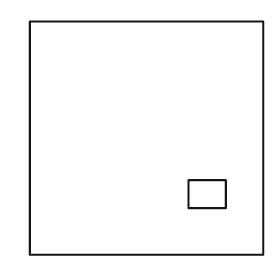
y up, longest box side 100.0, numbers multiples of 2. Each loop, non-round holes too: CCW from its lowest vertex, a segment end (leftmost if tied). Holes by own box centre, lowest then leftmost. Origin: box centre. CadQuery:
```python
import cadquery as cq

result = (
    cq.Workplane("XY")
    .moveTo(-50.0, -50.0)
    .lineTo(50.0, -50.0)
    .lineTo(50.0, 50.0)
    .lineTo(-50.0, 50.0)
    .close()
    .moveTo(18.0, -30.0)
    .lineTo(34.0, -30.0)
    .lineTo(34.0, -18.0)
    .lineTo(18.0, -18.0)
    .close()
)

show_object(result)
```